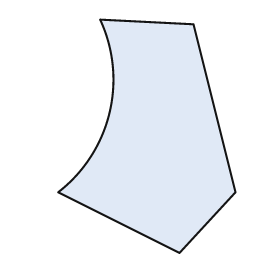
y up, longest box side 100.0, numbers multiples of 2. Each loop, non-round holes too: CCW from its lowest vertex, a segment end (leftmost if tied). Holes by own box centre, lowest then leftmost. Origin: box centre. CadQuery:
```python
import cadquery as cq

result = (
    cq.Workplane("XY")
    .moveTo(14.0, -50.0)
    .lineTo(38.0, -24.0)
    .lineTo(20.0, 48.0)
    .lineTo(-20.0, 50.0)
    .threePointArc((-16.0, 10.0), (-38.0, -24.0))
    .close()
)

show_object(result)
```